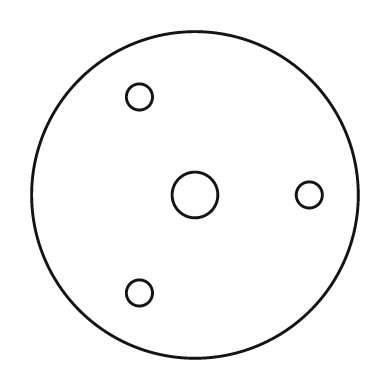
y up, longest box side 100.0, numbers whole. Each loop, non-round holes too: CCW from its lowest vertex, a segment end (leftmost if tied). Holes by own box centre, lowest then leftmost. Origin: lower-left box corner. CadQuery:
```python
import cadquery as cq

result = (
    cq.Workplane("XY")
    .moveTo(50.0, 50.0)
    .circle(50.0)
    .moveTo(33.0, 20.0)
    .circle(4.0)
    .moveTo(50.0, 50.0)
    .circle(7.0)
    .moveTo(85.0, 50.0)
    .circle(4.0)
    .moveTo(33.0, 80.0)
    .circle(4.0)
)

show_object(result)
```